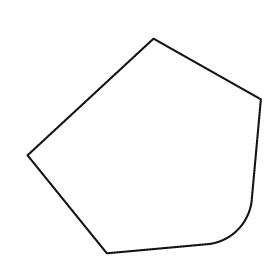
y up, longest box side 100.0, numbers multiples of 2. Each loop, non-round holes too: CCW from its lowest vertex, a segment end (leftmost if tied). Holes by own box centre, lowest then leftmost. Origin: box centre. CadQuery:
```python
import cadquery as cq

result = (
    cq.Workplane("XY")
    .moveTo(-16.0, -46.0)
    .lineTo(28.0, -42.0)
    .threePointArc((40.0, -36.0), (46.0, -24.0))
    .lineTo(50.0, 20.0)
    .lineTo(4.0, 46.0)
    .lineTo(-50.0, -4.0)
    .close()
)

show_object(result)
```